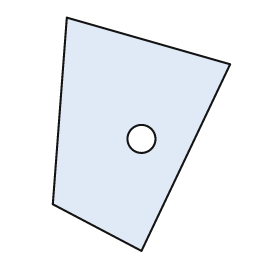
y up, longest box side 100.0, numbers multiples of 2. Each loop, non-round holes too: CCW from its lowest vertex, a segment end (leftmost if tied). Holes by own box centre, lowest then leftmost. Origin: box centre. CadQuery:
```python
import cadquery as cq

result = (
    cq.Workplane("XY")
    .moveTo(0.0, -50.0)
    .lineTo(38.0, 30.0)
    .lineTo(-32.0, 50.0)
    .lineTo(-38.0, -30.0)
    .close()
    .moveTo(0.0, -2.0)
    .circle(6.0)
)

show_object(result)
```